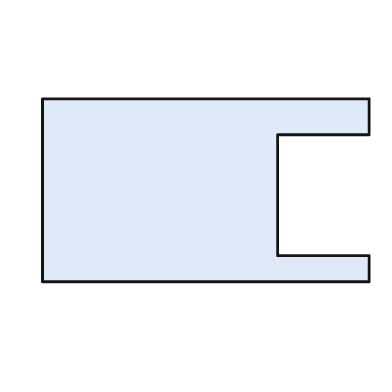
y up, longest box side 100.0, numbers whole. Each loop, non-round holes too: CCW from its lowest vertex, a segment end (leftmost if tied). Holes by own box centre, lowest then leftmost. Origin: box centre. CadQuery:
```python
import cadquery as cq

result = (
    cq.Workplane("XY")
    .moveTo(-50.0, -28.0)
    .lineTo(50.0, -28.0)
    .lineTo(50.0, -20.0)
    .lineTo(22.0, -20.0)
    .lineTo(22.0, 17.0)
    .lineTo(50.0, 17.0)
    .lineTo(50.0, 28.0)
    .lineTo(-50.0, 28.0)
    .close()
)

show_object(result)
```